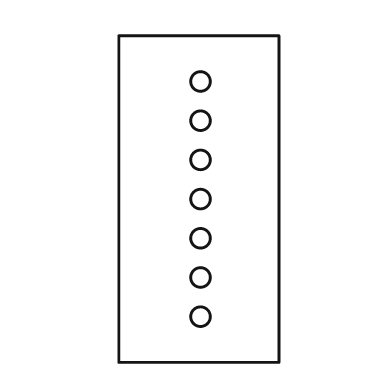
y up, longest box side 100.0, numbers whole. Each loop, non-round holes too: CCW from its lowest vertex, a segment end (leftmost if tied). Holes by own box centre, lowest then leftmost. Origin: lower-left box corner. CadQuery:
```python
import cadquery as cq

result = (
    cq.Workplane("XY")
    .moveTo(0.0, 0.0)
    .lineTo(49.0, 0.0)
    .lineTo(49.0, 100.0)
    .lineTo(0.0, 100.0)
    .close()
    .moveTo(25.0, 14.0)
    .circle(3.0)
    .moveTo(25.0, 26.0)
    .circle(3.0)
    .moveTo(25.0, 38.0)
    .circle(3.0)
    .moveTo(25.0, 50.0)
    .circle(3.0)
    .moveTo(25.0, 62.0)
    .circle(3.0)
    .moveTo(25.0, 74.0)
    .circle(3.0)
    .moveTo(25.0, 86.0)
    .circle(3.0)
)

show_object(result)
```